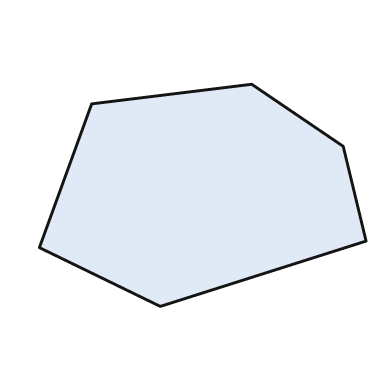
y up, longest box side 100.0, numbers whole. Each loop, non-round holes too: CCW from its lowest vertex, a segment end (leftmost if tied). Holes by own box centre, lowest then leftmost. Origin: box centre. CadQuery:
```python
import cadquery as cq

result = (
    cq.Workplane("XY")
    .moveTo(-13.0, -34.0)
    .lineTo(50.0, -14.0)
    .lineTo(43.0, 15.0)
    .lineTo(15.0, 34.0)
    .lineTo(-34.0, 28.0)
    .lineTo(-50.0, -16.0)
    .close()
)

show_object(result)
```